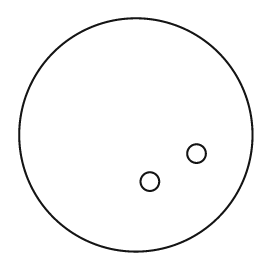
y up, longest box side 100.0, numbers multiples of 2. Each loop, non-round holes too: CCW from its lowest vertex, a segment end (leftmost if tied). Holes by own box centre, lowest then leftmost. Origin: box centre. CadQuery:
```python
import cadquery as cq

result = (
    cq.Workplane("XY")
    .moveTo(0.0, 0.0)
    .circle(50.0)
    .moveTo(6.0, -20.0)
    .circle(4.0)
    .moveTo(26.0, -8.0)
    .circle(4.0)
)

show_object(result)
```